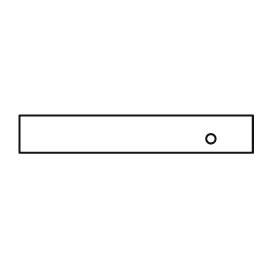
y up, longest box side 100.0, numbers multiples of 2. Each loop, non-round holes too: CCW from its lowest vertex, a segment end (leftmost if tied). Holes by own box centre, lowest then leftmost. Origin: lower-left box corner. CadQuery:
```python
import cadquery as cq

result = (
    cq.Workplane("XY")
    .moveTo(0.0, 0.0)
    .lineTo(100.0, 0.0)
    .lineTo(100.0, 16.0)
    .lineTo(0.0, 16.0)
    .close()
    .moveTo(82.0, 6.0)
    .circle(2.0)
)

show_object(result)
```